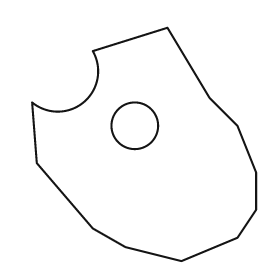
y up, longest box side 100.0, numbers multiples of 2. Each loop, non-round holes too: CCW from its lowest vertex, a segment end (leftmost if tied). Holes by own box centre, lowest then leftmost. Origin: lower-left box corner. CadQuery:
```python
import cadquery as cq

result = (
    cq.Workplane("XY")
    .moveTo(64.0, 0.0)
    .lineTo(88.0, 10.0)
    .lineTo(96.0, 22.0)
    .lineTo(96.0, 38.0)
    .lineTo(88.0, 58.0)
    .lineTo(76.0, 70.0)
    .lineTo(58.0, 100.0)
    .lineTo(26.0, 90.0)
    .threePointArc((22.0, 68.0), (0.0, 68.0))
    .lineTo(2.0, 42.0)
    .lineTo(26.0, 14.0)
    .lineTo(40.0, 6.0)
    .close()
    .moveTo(44.0, 58.0)
    .circle(10.0)
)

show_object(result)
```